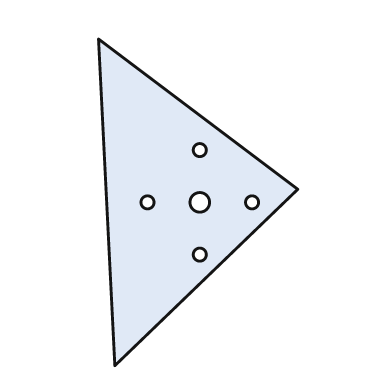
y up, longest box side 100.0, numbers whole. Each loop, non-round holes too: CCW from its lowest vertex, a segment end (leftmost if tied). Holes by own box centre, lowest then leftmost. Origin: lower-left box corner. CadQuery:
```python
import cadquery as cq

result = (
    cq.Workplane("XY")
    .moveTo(5.0, 0.0)
    .lineTo(61.0, 54.0)
    .lineTo(0.0, 100.0)
    .close()
    .moveTo(31.0, 34.0)
    .circle(2.0)
    .moveTo(15.0, 50.0)
    .circle(2.0)
    .moveTo(31.0, 50.0)
    .circle(3.0)
    .moveTo(47.0, 50.0)
    .circle(2.0)
    .moveTo(31.0, 66.0)
    .circle(2.0)
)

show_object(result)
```